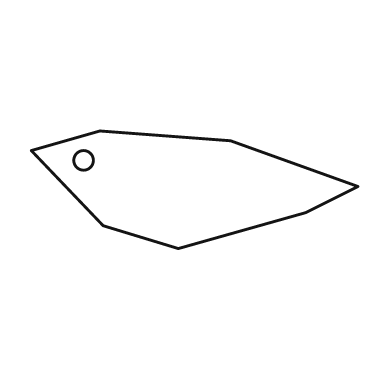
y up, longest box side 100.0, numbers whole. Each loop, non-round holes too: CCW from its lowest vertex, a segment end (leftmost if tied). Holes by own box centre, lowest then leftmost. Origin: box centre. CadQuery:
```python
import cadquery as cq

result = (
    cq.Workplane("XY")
    .moveTo(-5.0, -18.0)
    .lineTo(34.0, -7.0)
    .lineTo(50.0, 1.0)
    .lineTo(11.0, 15.0)
    .lineTo(-29.0, 18.0)
    .lineTo(-50.0, 12.0)
    .lineTo(-28.0, -11.0)
    .close()
    .moveTo(-34.0, 9.0)
    .circle(3.0)
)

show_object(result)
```